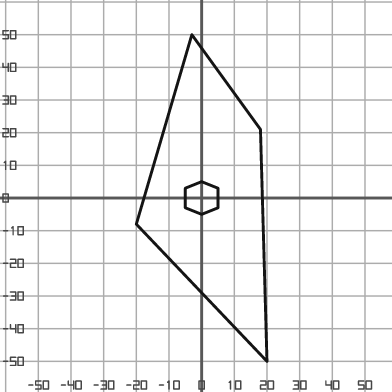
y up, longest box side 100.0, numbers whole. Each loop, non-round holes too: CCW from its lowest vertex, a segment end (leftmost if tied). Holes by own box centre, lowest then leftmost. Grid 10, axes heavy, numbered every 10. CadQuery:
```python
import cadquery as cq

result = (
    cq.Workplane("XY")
    .moveTo(20.0, -50.0)
    .lineTo(18.0, 21.0)
    .lineTo(-3.0, 50.0)
    .lineTo(-20.0, -8.0)
    .close()
    .moveTo(0.0, -5.0)
    .lineTo(5.0, -3.0)
    .lineTo(5.0, 3.0)
    .lineTo(0.0, 5.0)
    .lineTo(-5.0, 3.0)
    .lineTo(-5.0, -3.0)
    .close()
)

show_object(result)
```